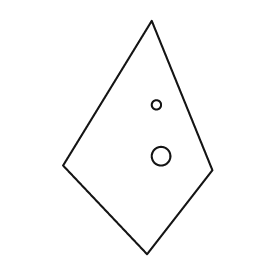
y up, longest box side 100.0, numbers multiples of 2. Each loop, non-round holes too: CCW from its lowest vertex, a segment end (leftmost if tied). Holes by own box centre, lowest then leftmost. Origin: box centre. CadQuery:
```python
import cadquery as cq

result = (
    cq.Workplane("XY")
    .moveTo(4.0, -50.0)
    .lineTo(32.0, -14.0)
    .lineTo(6.0, 50.0)
    .lineTo(-32.0, -12.0)
    .close()
    .moveTo(10.0, -8.0)
    .circle(4.0)
    .moveTo(8.0, 14.0)
    .circle(2.0)
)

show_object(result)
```